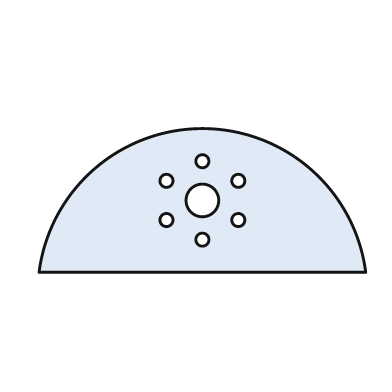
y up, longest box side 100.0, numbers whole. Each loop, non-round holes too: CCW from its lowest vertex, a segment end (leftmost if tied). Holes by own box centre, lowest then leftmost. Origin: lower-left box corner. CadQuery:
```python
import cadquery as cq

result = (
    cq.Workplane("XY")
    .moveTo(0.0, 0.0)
    .lineTo(100.0, 0.0)
    .threePointArc((50.0, 44.0), (0.0, 0.0))
    .close()
    .moveTo(50.0, 10.0)
    .circle(2.0)
    .moveTo(39.0, 16.0)
    .circle(2.0)
    .moveTo(61.0, 16.0)
    .circle(2.0)
    .moveTo(50.0, 22.0)
    .circle(5.0)
    .moveTo(39.0, 28.0)
    .circle(2.0)
    .moveTo(61.0, 28.0)
    .circle(2.0)
    .moveTo(50.0, 34.0)
    .circle(2.0)
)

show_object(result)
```